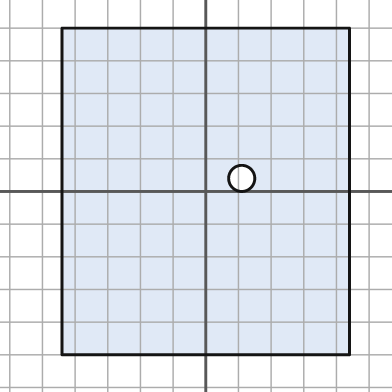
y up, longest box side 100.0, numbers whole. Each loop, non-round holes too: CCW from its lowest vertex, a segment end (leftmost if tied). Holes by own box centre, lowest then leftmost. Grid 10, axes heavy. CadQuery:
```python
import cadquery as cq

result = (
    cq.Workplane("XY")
    .moveTo(-44.0, -50.0)
    .lineTo(44.0, -50.0)
    .lineTo(44.0, 50.0)
    .lineTo(-44.0, 50.0)
    .close()
    .moveTo(11.0, 4.0)
    .circle(4.0)
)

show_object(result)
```